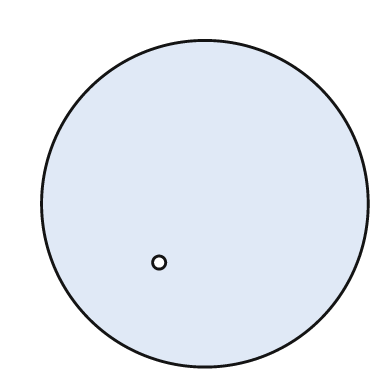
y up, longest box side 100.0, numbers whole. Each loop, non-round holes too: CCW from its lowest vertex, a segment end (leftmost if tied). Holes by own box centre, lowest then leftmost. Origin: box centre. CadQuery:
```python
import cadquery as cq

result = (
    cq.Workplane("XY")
    .moveTo(0.0, 0.0)
    .circle(50.0)
    .moveTo(-14.0, -18.0)
    .circle(2.0)
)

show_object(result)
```